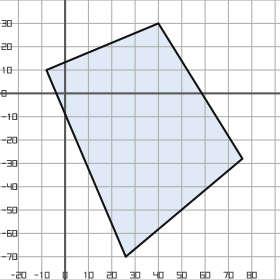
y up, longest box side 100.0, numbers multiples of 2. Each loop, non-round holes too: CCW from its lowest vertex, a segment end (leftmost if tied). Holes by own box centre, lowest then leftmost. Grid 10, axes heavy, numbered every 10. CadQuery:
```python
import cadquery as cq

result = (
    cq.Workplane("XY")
    .moveTo(26.0, -70.0)
    .lineTo(76.0, -28.0)
    .lineTo(40.0, 30.0)
    .lineTo(-8.0, 10.0)
    .close()
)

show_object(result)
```